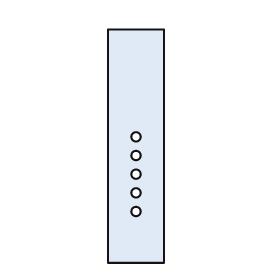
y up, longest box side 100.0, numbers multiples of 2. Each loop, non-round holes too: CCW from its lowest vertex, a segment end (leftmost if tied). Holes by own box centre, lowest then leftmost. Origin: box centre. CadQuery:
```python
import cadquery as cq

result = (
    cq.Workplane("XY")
    .moveTo(-12.0, -50.0)
    .lineTo(12.0, -50.0)
    .lineTo(12.0, 50.0)
    .lineTo(-12.0, 50.0)
    .close()
    .moveTo(0.0, -28.0)
    .circle(2.0)
    .moveTo(0.0, -20.0)
    .circle(2.0)
    .moveTo(0.0, -12.0)
    .circle(2.0)
    .moveTo(0.0, -4.0)
    .circle(2.0)
    .moveTo(0.0, 4.0)
    .circle(2.0)
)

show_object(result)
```